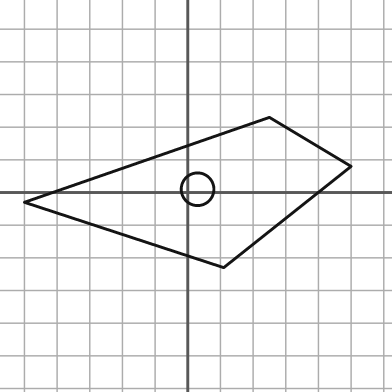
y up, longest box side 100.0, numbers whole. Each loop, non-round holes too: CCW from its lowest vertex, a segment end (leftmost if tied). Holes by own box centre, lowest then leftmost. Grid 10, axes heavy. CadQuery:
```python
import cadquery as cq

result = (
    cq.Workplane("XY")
    .moveTo(11.0, -23.0)
    .lineTo(50.0, 8.0)
    .lineTo(25.0, 23.0)
    .lineTo(-50.0, -3.0)
    .close()
    .moveTo(3.0, 1.0)
    .circle(5.0)
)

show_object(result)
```